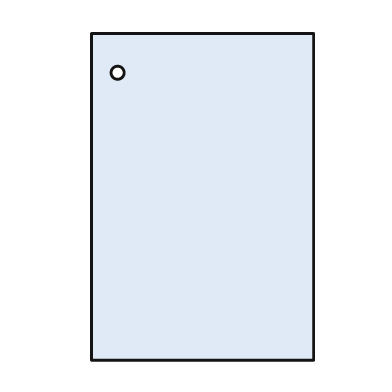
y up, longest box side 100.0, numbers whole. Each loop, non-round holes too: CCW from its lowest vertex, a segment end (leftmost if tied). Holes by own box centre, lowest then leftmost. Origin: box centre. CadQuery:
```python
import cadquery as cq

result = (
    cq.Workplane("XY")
    .moveTo(-34.0, -50.0)
    .lineTo(34.0, -50.0)
    .lineTo(34.0, 50.0)
    .lineTo(-34.0, 50.0)
    .close()
    .moveTo(-26.0, 38.0)
    .circle(2.0)
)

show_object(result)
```